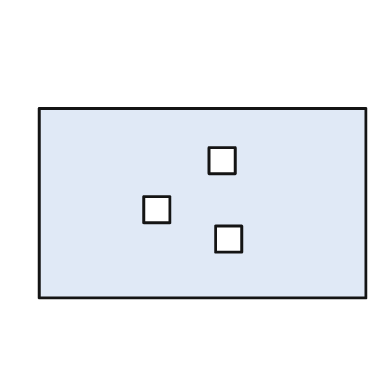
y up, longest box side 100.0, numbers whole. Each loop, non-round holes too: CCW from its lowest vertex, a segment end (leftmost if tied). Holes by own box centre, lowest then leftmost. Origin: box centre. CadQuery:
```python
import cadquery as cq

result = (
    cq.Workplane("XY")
    .moveTo(-50.0, -29.0)
    .lineTo(50.0, -29.0)
    .lineTo(50.0, 29.0)
    .lineTo(-50.0, 29.0)
    .close()
    .moveTo(4.0, -15.0)
    .lineTo(12.0, -15.0)
    .lineTo(12.0, -7.0)
    .lineTo(4.0, -7.0)
    .close()
    .moveTo(-18.0, -6.0)
    .lineTo(-10.0, -6.0)
    .lineTo(-10.0, 2.0)
    .lineTo(-18.0, 2.0)
    .close()
    .moveTo(2.0, 9.0)
    .lineTo(10.0, 9.0)
    .lineTo(10.0, 17.0)
    .lineTo(2.0, 17.0)
    .close()
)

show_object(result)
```